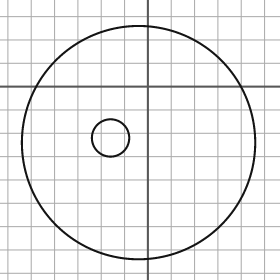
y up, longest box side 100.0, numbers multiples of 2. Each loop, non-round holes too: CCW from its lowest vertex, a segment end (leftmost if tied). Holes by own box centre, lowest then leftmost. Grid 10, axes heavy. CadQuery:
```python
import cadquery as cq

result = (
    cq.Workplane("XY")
    .moveTo(-4.0, -24.0)
    .circle(50.0)
    .moveTo(-16.0, -22.0)
    .circle(8.0)
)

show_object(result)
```